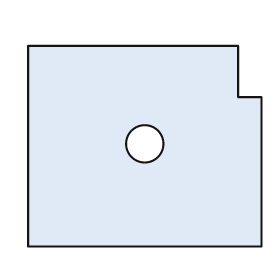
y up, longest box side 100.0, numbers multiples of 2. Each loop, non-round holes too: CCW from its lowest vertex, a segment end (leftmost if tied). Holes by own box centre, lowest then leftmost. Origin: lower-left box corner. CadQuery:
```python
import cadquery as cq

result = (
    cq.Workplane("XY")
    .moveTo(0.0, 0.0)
    .lineTo(100.0, 0.0)
    .lineTo(100.0, 64.0)
    .lineTo(90.0, 64.0)
    .lineTo(90.0, 86.0)
    .lineTo(0.0, 86.0)
    .close()
    .moveTo(50.0, 44.0)
    .circle(8.0)
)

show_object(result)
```